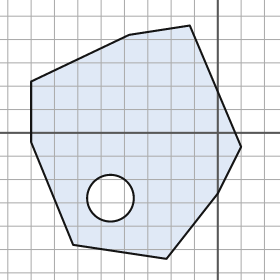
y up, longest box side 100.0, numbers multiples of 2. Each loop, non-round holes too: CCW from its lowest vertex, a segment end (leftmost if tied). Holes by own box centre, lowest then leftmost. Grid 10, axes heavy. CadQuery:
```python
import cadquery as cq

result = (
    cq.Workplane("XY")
    .moveTo(-22.0, -54.0)
    .lineTo(0.0, -26.0)
    .lineTo(10.0, -6.0)
    .lineTo(-12.0, 46.0)
    .lineTo(-38.0, 42.0)
    .lineTo(-80.0, 22.0)
    .lineTo(-80.0, -4.0)
    .lineTo(-62.0, -48.0)
    .close()
    .moveTo(-46.0, -28.0)
    .circle(10.0)
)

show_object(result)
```